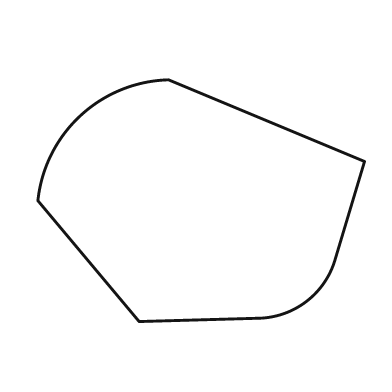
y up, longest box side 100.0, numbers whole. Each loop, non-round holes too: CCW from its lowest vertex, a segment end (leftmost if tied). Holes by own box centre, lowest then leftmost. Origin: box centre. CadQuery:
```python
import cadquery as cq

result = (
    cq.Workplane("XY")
    .moveTo(-19.0, -37.0)
    .lineTo(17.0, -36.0)
    .threePointArc((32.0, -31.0), (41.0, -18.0))
    .lineTo(50.0, 12.0)
    .lineTo(-10.0, 37.0)
    .threePointArc((-37.0, 26.0), (-50.0, 0.0))
    .close()
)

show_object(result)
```